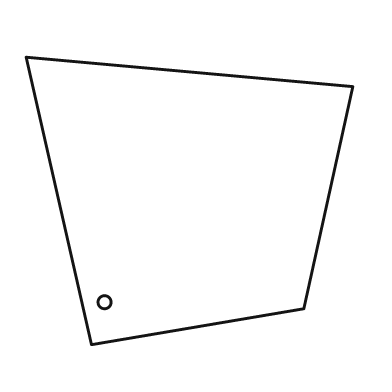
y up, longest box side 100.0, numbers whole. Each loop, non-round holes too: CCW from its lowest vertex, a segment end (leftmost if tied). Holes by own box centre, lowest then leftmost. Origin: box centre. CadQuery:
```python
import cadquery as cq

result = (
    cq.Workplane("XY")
    .moveTo(-30.0, -44.0)
    .lineTo(35.0, -33.0)
    .lineTo(50.0, 35.0)
    .lineTo(-50.0, 44.0)
    .close()
    .moveTo(-26.0, -31.0)
    .circle(2.0)
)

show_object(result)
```